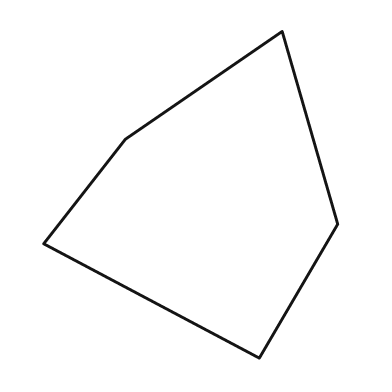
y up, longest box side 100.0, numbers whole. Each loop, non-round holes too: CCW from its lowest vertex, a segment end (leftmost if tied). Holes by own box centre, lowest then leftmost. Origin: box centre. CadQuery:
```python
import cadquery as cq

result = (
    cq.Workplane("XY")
    .moveTo(21.0, -50.0)
    .lineTo(45.0, -9.0)
    .lineTo(28.0, 50.0)
    .lineTo(-20.0, 17.0)
    .lineTo(-45.0, -15.0)
    .close()
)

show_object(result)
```